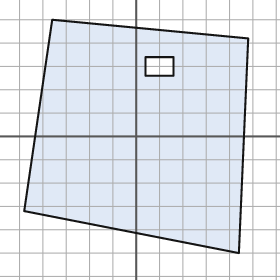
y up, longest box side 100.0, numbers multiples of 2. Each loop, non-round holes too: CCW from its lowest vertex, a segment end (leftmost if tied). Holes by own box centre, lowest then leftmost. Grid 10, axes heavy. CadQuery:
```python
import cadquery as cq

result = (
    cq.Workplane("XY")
    .moveTo(44.0, -50.0)
    .lineTo(48.0, 42.0)
    .lineTo(-36.0, 50.0)
    .lineTo(-48.0, -32.0)
    .close()
    .moveTo(4.0, 26.0)
    .lineTo(16.0, 26.0)
    .lineTo(16.0, 34.0)
    .lineTo(4.0, 34.0)
    .close()
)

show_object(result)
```